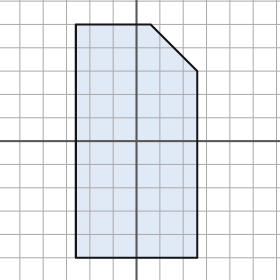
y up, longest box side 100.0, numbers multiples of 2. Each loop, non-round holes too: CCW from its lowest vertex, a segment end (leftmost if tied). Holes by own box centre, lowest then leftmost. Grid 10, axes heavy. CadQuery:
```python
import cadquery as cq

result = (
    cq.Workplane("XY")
    .moveTo(-26.0, -50.0)
    .lineTo(26.0, -50.0)
    .lineTo(26.0, 30.0)
    .lineTo(6.0, 50.0)
    .lineTo(-26.0, 50.0)
    .close()
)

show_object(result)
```